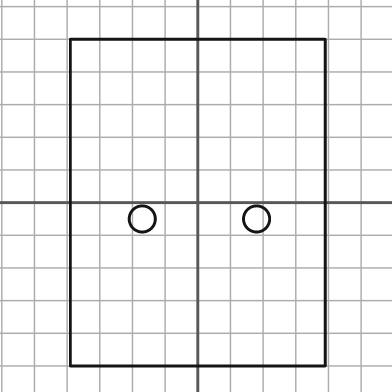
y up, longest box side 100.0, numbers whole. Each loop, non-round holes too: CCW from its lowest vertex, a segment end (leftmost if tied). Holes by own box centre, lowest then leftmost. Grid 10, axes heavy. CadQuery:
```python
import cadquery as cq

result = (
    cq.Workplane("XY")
    .moveTo(-39.0, -50.0)
    .lineTo(39.0, -50.0)
    .lineTo(39.0, 50.0)
    .lineTo(-39.0, 50.0)
    .close()
    .moveTo(-17.0, -5.0)
    .circle(4.0)
    .moveTo(18.0, -5.0)
    .circle(4.0)
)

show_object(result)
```